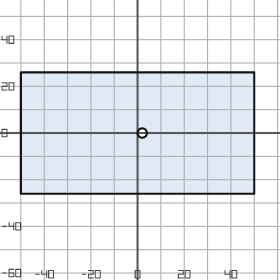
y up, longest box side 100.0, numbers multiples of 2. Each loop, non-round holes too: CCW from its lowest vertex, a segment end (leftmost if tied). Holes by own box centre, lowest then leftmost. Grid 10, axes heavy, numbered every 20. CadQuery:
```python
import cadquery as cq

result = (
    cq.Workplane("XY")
    .moveTo(-50.0, -26.0)
    .lineTo(50.0, -26.0)
    .lineTo(50.0, 26.0)
    .lineTo(-50.0, 26.0)
    .close()
    .moveTo(2.0, 0.0)
    .circle(2.0)
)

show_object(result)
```